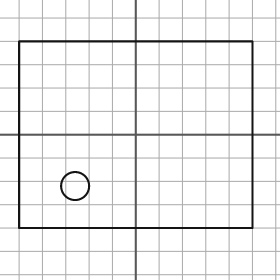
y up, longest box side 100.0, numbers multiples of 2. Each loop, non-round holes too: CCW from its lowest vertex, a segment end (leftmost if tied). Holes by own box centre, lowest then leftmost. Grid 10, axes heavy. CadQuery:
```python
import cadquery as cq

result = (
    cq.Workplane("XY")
    .moveTo(-50.0, -40.0)
    .lineTo(50.0, -40.0)
    .lineTo(50.0, 40.0)
    .lineTo(-50.0, 40.0)
    .close()
    .moveTo(-26.0, -22.0)
    .circle(6.0)
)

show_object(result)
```